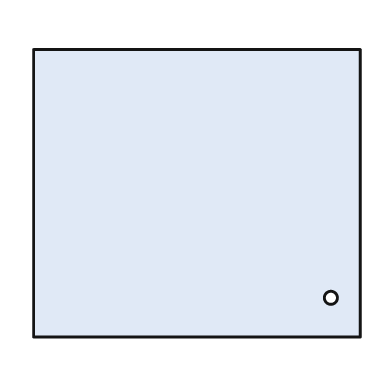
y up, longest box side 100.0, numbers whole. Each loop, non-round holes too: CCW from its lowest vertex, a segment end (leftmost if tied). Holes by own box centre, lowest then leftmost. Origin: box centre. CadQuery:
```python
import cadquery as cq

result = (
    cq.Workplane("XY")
    .moveTo(-50.0, -44.0)
    .lineTo(50.0, -44.0)
    .lineTo(50.0, 44.0)
    .lineTo(-50.0, 44.0)
    .close()
    .moveTo(41.0, -32.0)
    .circle(2.0)
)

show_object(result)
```